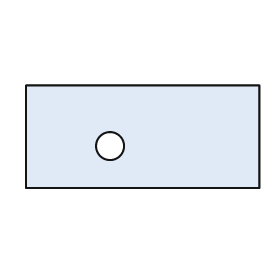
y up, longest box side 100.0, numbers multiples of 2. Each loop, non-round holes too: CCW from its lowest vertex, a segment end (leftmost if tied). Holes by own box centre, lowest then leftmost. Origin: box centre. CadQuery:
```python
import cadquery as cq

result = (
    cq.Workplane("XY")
    .moveTo(-50.0, -22.0)
    .lineTo(50.0, -22.0)
    .lineTo(50.0, 22.0)
    .lineTo(-50.0, 22.0)
    .close()
    .moveTo(-14.0, -4.0)
    .circle(6.0)
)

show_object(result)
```